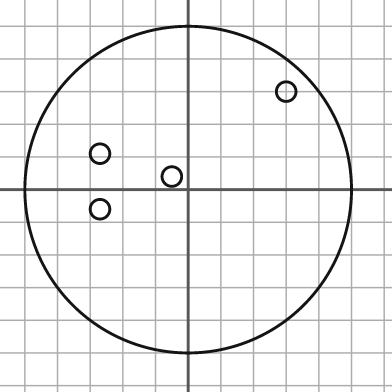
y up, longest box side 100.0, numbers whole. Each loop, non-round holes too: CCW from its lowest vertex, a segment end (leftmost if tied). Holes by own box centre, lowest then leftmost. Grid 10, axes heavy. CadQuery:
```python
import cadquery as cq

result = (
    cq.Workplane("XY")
    .moveTo(0.0, 0.0)
    .circle(50.0)
    .moveTo(-27.0, -6.0)
    .circle(3.0)
    .moveTo(-5.0, 4.0)
    .circle(3.0)
    .moveTo(-27.0, 11.0)
    .circle(3.0)
    .moveTo(30.0, 30.0)
    .circle(3.0)
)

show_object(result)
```